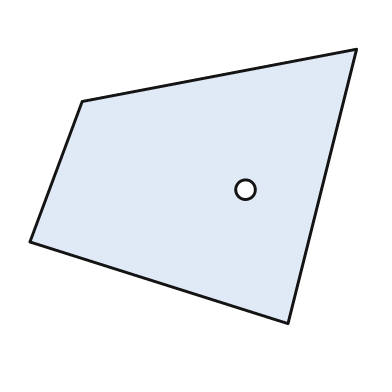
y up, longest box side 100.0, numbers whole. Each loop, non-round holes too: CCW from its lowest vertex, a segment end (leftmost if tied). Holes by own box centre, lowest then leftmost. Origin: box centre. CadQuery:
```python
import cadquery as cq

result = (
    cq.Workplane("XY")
    .moveTo(29.0, -42.0)
    .lineTo(50.0, 42.0)
    .lineTo(-34.0, 26.0)
    .lineTo(-50.0, -17.0)
    .close()
    .moveTo(16.0, -1.0)
    .circle(3.0)
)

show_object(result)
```